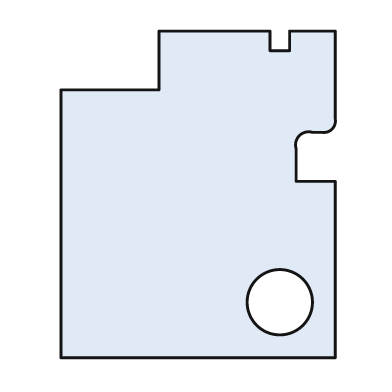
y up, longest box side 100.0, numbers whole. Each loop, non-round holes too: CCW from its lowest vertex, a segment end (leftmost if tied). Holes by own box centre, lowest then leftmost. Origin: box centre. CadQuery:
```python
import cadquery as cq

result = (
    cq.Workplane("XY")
    .moveTo(-42.0, -50.0)
    .lineTo(42.0, -50.0)
    .lineTo(42.0, 4.0)
    .lineTo(30.0, 4.0)
    .lineTo(30.0, 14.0)
    .threePointArc((31.0, 18.0), (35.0, 19.0))
    .lineTo(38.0, 19.0)
    .threePointArc((41.0, 20.0), (42.0, 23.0))
    .lineTo(42.0, 50.0)
    .lineTo(28.0, 50.0)
    .lineTo(28.0, 44.0)
    .lineTo(22.0, 44.0)
    .lineTo(22.0, 50.0)
    .lineTo(-12.0, 50.0)
    .lineTo(-12.0, 32.0)
    .lineTo(-42.0, 32.0)
    .close()
    .moveTo(25.0, -33.0)
    .circle(10.0)
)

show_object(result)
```